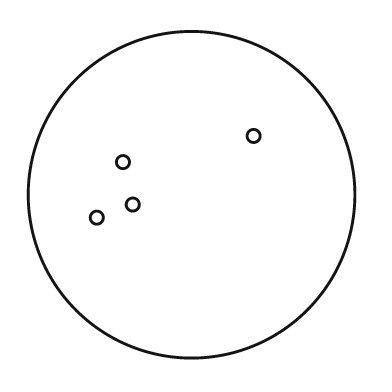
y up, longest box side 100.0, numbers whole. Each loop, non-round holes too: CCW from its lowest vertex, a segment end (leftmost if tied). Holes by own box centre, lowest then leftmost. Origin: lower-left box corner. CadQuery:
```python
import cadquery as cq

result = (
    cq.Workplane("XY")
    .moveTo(50.0, 50.0)
    .circle(50.0)
    .moveTo(21.0, 43.0)
    .circle(2.0)
    .moveTo(32.0, 47.0)
    .circle(2.0)
    .moveTo(29.0, 60.0)
    .circle(2.0)
    .moveTo(69.0, 68.0)
    .circle(2.0)
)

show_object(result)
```